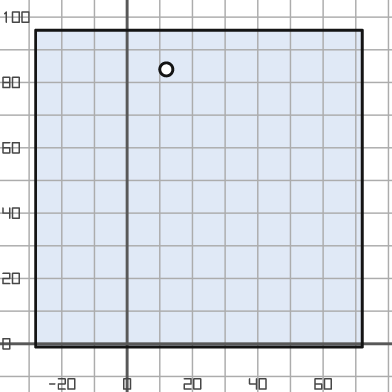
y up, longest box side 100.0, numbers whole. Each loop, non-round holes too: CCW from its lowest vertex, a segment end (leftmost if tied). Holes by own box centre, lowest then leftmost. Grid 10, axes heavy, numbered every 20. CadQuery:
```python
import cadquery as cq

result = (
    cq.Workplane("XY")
    .moveTo(-28.0, -1.0)
    .lineTo(72.0, -1.0)
    .lineTo(72.0, 96.0)
    .lineTo(-28.0, 96.0)
    .close()
    .moveTo(12.0, 84.0)
    .circle(2.0)
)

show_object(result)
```